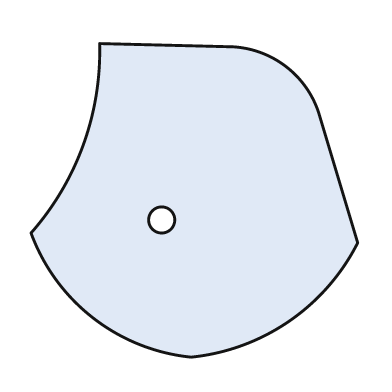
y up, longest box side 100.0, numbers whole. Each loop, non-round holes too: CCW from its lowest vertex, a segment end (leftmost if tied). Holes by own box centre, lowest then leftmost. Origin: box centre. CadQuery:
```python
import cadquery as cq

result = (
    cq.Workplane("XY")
    .moveTo(-1.0, -48.0)
    .threePointArc((29.0, -37.0), (50.0, -13.0))
    .lineTo(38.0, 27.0)
    .threePointArc((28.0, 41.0), (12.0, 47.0))
    .lineTo(-29.0, 48.0)
    .threePointArc((-34.0, 17.0), (-50.0, -10.0))
    .threePointArc((-31.0, -36.0), (-1.0, -48.0))
    .close()
    .moveTo(-10.0, -6.0)
    .circle(4.0)
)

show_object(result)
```